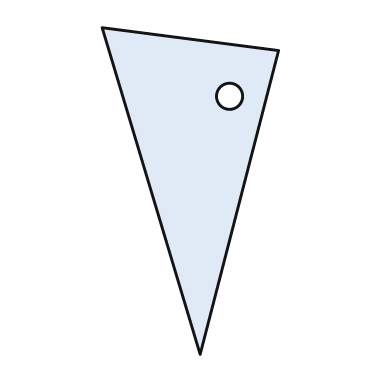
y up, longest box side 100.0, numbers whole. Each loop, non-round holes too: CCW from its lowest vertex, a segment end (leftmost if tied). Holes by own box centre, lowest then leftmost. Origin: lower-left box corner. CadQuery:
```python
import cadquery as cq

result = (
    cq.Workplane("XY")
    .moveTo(30.0, 0.0)
    .lineTo(54.0, 93.0)
    .lineTo(0.0, 100.0)
    .close()
    .moveTo(39.0, 79.0)
    .circle(4.0)
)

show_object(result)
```